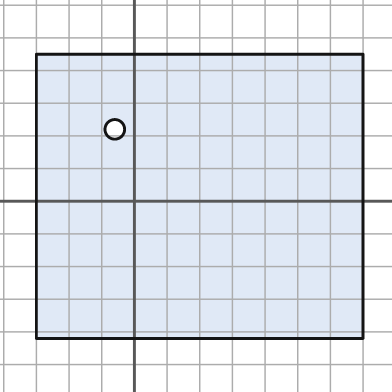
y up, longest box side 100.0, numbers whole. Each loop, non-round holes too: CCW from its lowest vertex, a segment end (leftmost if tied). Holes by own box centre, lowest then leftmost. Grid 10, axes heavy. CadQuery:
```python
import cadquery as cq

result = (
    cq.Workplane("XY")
    .moveTo(-30.0, -42.0)
    .lineTo(70.0, -42.0)
    .lineTo(70.0, 45.0)
    .lineTo(-30.0, 45.0)
    .close()
    .moveTo(-6.0, 22.0)
    .circle(3.0)
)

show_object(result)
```